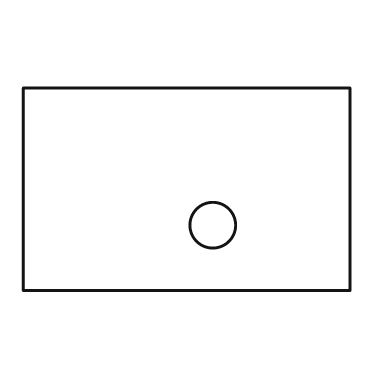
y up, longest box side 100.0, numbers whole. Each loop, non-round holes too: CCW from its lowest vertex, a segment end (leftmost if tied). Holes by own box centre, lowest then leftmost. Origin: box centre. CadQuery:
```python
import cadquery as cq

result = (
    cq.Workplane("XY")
    .moveTo(-50.0, -31.0)
    .lineTo(50.0, -31.0)
    .lineTo(50.0, 31.0)
    .lineTo(-50.0, 31.0)
    .close()
    .moveTo(8.0, -11.0)
    .circle(7.0)
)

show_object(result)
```